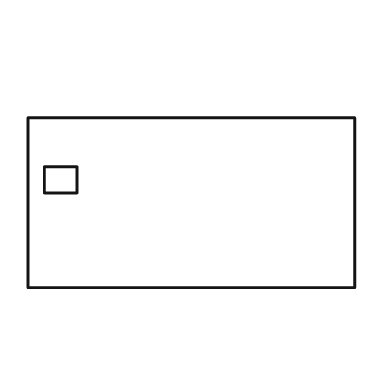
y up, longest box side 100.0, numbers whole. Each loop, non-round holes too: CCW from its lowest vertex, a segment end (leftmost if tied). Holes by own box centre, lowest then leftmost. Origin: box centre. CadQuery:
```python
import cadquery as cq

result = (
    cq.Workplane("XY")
    .moveTo(-50.0, -26.0)
    .lineTo(50.0, -26.0)
    .lineTo(50.0, 26.0)
    .lineTo(-50.0, 26.0)
    .close()
    .moveTo(-45.0, 3.0)
    .lineTo(-35.0, 3.0)
    .lineTo(-35.0, 11.0)
    .lineTo(-45.0, 11.0)
    .close()
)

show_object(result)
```